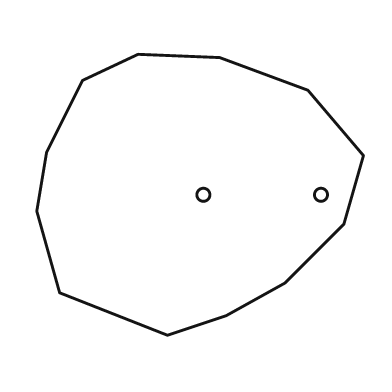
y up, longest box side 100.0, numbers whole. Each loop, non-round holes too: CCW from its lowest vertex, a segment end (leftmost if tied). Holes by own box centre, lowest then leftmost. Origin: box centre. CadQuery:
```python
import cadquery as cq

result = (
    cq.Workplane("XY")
    .moveTo(-10.0, -43.0)
    .lineTo(8.0, -37.0)
    .lineTo(26.0, -27.0)
    .lineTo(44.0, -9.0)
    .lineTo(50.0, 12.0)
    .lineTo(33.0, 32.0)
    .lineTo(6.0, 42.0)
    .lineTo(-19.0, 43.0)
    .lineTo(-36.0, 35.0)
    .lineTo(-47.0, 13.0)
    .lineTo(-50.0, -5.0)
    .lineTo(-43.0, -30.0)
    .close()
    .moveTo(1.0, 0.0)
    .circle(2.0)
    .moveTo(37.0, 0.0)
    .circle(2.0)
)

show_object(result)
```